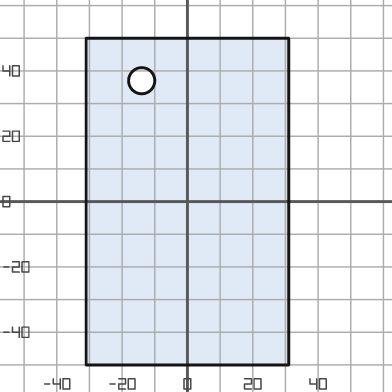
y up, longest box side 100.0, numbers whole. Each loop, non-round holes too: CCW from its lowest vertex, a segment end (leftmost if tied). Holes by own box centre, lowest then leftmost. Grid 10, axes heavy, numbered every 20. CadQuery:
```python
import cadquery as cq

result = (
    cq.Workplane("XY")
    .moveTo(-31.0, -50.0)
    .lineTo(31.0, -50.0)
    .lineTo(31.0, 50.0)
    .lineTo(-31.0, 50.0)
    .close()
    .moveTo(-14.0, 37.0)
    .circle(4.0)
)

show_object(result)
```